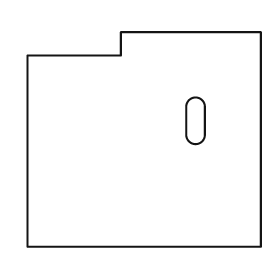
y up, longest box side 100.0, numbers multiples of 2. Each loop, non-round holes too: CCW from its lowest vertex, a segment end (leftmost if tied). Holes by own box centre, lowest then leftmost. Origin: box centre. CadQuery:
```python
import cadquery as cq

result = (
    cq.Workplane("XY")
    .moveTo(-50.0, -46.0)
    .lineTo(50.0, -46.0)
    .lineTo(50.0, 46.0)
    .lineTo(-10.0, 46.0)
    .lineTo(-10.0, 36.0)
    .lineTo(-50.0, 36.0)
    .close()
    .moveTo(18.0, 2.0)
    .threePointArc((22.0, -2.0), (26.0, 2.0))
    .lineTo(26.0, 14.0)
    .threePointArc((22.0, 18.0), (18.0, 14.0))
    .close()
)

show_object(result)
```